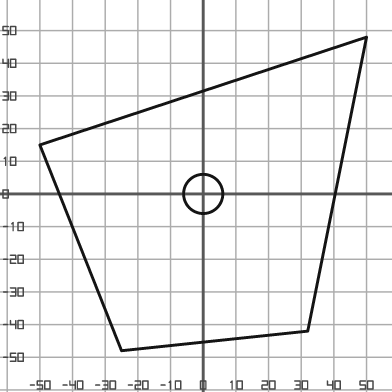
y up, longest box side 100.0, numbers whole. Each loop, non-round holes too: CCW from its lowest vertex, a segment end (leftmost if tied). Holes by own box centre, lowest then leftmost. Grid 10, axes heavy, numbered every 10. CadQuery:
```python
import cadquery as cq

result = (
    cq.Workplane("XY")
    .moveTo(-25.0, -48.0)
    .lineTo(32.0, -42.0)
    .lineTo(50.0, 48.0)
    .lineTo(-50.0, 15.0)
    .close()
    .moveTo(0.0, 0.0)
    .circle(6.0)
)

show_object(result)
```